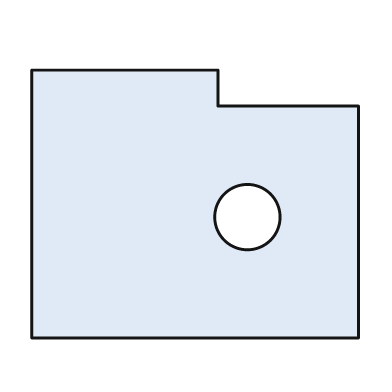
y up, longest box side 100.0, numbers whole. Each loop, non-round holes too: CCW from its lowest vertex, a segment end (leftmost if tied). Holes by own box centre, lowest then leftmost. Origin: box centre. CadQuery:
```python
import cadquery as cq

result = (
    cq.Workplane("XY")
    .moveTo(-50.0, -41.0)
    .lineTo(50.0, -41.0)
    .lineTo(50.0, 30.0)
    .lineTo(7.0, 30.0)
    .lineTo(7.0, 41.0)
    .lineTo(-50.0, 41.0)
    .close()
    .moveTo(16.0, -4.0)
    .circle(10.0)
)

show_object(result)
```